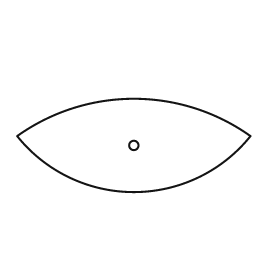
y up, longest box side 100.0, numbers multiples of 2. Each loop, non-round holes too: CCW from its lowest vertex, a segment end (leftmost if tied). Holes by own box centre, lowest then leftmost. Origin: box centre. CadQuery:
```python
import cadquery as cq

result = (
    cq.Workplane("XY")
    .moveTo(-50.0, 4.0)
    .threePointArc((0.0, -20.0), (50.0, 4.0))
    .threePointArc((0.0, 20.0), (-50.0, 4.0))
    .close()
    .moveTo(0.0, 0.0)
    .circle(2.0)
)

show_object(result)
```